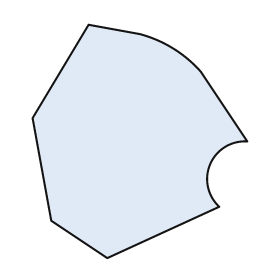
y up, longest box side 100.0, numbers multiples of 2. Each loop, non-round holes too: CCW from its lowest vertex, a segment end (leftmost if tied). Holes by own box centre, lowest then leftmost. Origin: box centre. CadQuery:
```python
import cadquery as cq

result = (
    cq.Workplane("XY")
    .moveTo(-14.0, -50.0)
    .lineTo(34.0, -28.0)
    .threePointArc((30.0, -10.0), (46.0, 0.0))
    .lineTo(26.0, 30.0)
    .threePointArc((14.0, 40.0), (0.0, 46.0))
    .lineTo(-22.0, 50.0)
    .lineTo(-46.0, 10.0)
    .lineTo(-38.0, -34.0)
    .close()
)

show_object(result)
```